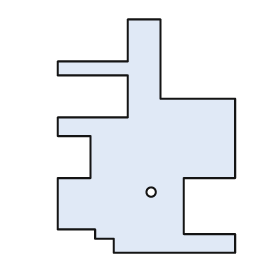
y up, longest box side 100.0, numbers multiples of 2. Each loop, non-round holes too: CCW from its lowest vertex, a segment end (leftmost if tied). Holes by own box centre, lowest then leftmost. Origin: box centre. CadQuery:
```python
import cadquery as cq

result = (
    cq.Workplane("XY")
    .moveTo(-14.0, -50.0)
    .lineTo(38.0, -50.0)
    .lineTo(38.0, -42.0)
    .lineTo(16.0, -42.0)
    .lineTo(16.0, -18.0)
    .lineTo(38.0, -18.0)
    .lineTo(38.0, 16.0)
    .lineTo(6.0, 16.0)
    .lineTo(6.0, 50.0)
    .lineTo(-8.0, 50.0)
    .lineTo(-8.0, 32.0)
    .lineTo(-38.0, 32.0)
    .lineTo(-38.0, 26.0)
    .lineTo(-8.0, 26.0)
    .lineTo(-8.0, 8.0)
    .lineTo(-38.0, 8.0)
    .lineTo(-38.0, 0.0)
    .lineTo(-24.0, 0.0)
    .lineTo(-24.0, -18.0)
    .lineTo(-38.0, -18.0)
    .lineTo(-38.0, -40.0)
    .lineTo(-22.0, -40.0)
    .lineTo(-22.0, -44.0)
    .lineTo(-14.0, -44.0)
    .close()
    .moveTo(2.0, -24.0)
    .circle(2.0)
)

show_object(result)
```